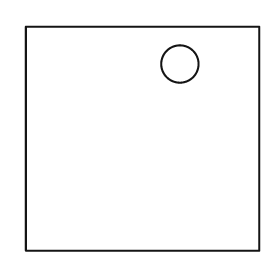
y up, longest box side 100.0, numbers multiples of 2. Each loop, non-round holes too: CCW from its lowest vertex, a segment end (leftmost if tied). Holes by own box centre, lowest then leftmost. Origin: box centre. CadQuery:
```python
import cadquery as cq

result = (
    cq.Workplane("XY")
    .moveTo(-50.0, -48.0)
    .lineTo(50.0, -48.0)
    .lineTo(50.0, 48.0)
    .lineTo(-50.0, 48.0)
    .close()
    .moveTo(16.0, 32.0)
    .circle(8.0)
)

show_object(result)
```